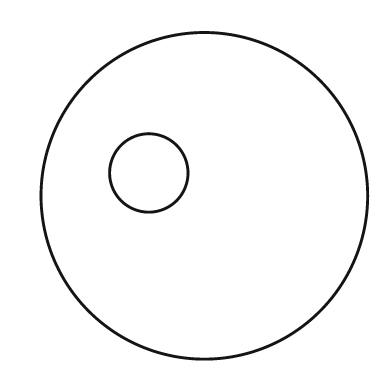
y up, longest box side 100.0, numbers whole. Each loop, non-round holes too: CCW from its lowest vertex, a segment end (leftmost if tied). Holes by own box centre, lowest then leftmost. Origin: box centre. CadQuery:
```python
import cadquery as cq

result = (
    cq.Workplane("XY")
    .moveTo(0.0, 0.0)
    .circle(50.0)
    .moveTo(-17.0, 7.0)
    .circle(12.0)
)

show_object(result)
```